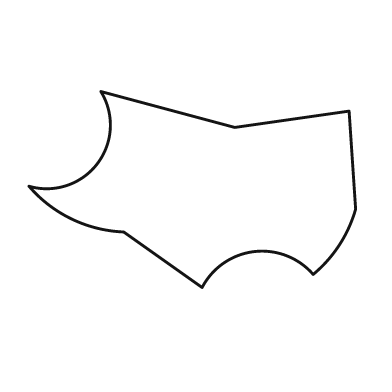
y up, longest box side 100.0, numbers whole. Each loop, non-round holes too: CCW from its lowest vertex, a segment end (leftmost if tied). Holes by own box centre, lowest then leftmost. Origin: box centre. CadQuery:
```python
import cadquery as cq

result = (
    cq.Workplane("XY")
    .moveTo(3.0, -30.0)
    .threePointArc((19.0, -19.0), (37.0, -26.0))
    .threePointArc((45.0, -17.0), (50.0, -6.0))
    .lineTo(48.0, 24.0)
    .lineTo(13.0, 19.0)
    .lineTo(-28.0, 30.0)
    .threePointArc((-29.0, 8.0), (-50.0, 1.0))
    .threePointArc((-37.0, -9.0), (-21.0, -13.0))
    .close()
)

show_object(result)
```